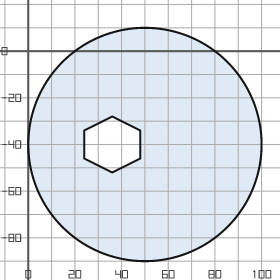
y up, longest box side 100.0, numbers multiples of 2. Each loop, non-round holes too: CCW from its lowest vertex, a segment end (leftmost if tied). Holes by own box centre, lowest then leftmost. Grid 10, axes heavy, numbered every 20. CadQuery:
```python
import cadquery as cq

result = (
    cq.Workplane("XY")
    .moveTo(50.0, -40.0)
    .circle(50.0)
    .moveTo(36.0, -52.0)
    .lineTo(48.0, -46.0)
    .lineTo(48.0, -34.0)
    .lineTo(36.0, -28.0)
    .lineTo(24.0, -34.0)
    .lineTo(24.0, -46.0)
    .close()
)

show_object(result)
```